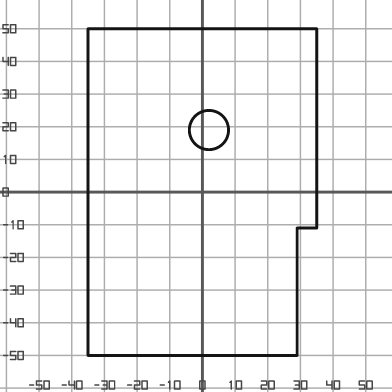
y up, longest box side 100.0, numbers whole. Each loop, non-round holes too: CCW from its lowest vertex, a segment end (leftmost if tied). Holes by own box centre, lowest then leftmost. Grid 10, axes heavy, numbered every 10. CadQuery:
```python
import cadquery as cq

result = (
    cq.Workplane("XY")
    .moveTo(-35.0, -50.0)
    .lineTo(29.0, -50.0)
    .lineTo(29.0, -11.0)
    .lineTo(35.0, -11.0)
    .lineTo(35.0, 50.0)
    .lineTo(-35.0, 50.0)
    .close()
    .moveTo(2.0, 19.0)
    .circle(6.0)
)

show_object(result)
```